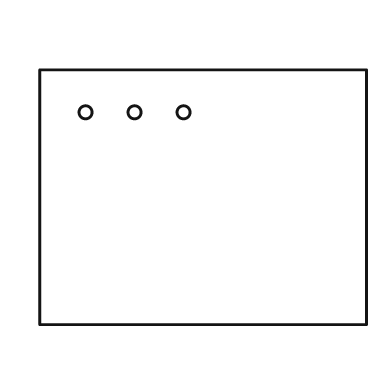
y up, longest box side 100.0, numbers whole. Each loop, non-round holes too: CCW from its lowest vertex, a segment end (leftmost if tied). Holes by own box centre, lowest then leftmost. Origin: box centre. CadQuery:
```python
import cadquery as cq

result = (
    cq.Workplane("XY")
    .moveTo(-50.0, -39.0)
    .lineTo(50.0, -39.0)
    .lineTo(50.0, 39.0)
    .lineTo(-50.0, 39.0)
    .close()
    .moveTo(-36.0, 26.0)
    .circle(2.0)
    .moveTo(-21.0, 26.0)
    .circle(2.0)
    .moveTo(-6.0, 26.0)
    .circle(2.0)
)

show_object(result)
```